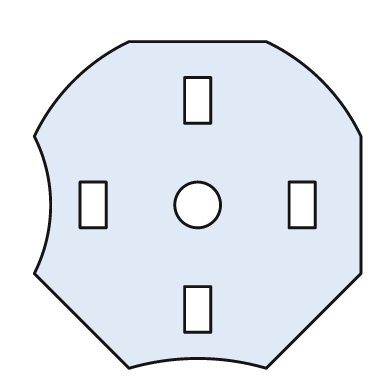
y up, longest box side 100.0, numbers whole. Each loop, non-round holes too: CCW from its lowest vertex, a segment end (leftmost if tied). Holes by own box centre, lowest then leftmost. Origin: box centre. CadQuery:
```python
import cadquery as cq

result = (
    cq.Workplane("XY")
    .moveTo(-21.0, -50.0)
    .threePointArc((0.0, -47.0), (21.0, -50.0))
    .lineTo(50.0, -21.0)
    .lineTo(50.0, 21.0)
    .threePointArc((38.0, 38.0), (21.0, 50.0))
    .lineTo(-21.0, 50.0)
    .threePointArc((-38.0, 38.0), (-50.0, 21.0))
    .threePointArc((-45.0, 0.0), (-50.0, -21.0))
    .close()
    .moveTo(-4.0, -39.0)
    .lineTo(4.0, -39.0)
    .lineTo(4.0, -25.0)
    .lineTo(-4.0, -25.0)
    .close()
    .moveTo(-36.0, -7.0)
    .lineTo(-28.0, -7.0)
    .lineTo(-28.0, 7.0)
    .lineTo(-36.0, 7.0)
    .close()
    .moveTo(0.0, 0.0)
    .circle(7.0)
    .moveTo(28.0, -7.0)
    .lineTo(36.0, -7.0)
    .lineTo(36.0, 7.0)
    .lineTo(28.0, 7.0)
    .close()
    .moveTo(-4.0, 25.0)
    .lineTo(4.0, 25.0)
    .lineTo(4.0, 39.0)
    .lineTo(-4.0, 39.0)
    .close()
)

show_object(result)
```